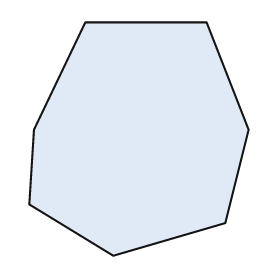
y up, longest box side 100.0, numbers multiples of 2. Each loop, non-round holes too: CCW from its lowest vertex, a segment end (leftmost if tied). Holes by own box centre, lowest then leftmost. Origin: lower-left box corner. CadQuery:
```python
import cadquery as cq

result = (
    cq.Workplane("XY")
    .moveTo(36.0, 0.0)
    .lineTo(84.0, 14.0)
    .lineTo(94.0, 54.0)
    .lineTo(76.0, 100.0)
    .lineTo(24.0, 100.0)
    .lineTo(2.0, 54.0)
    .lineTo(0.0, 22.0)
    .close()
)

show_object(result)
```